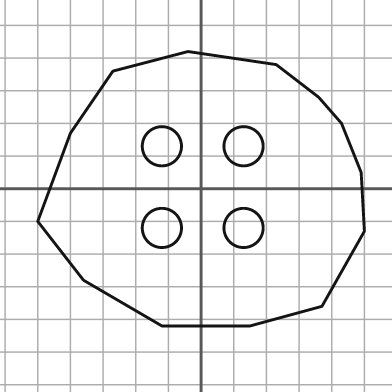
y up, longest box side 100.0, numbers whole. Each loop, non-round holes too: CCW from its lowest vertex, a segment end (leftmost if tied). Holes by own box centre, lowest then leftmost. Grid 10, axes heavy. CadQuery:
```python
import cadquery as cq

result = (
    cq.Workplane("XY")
    .moveTo(-12.0, -42.0)
    .lineTo(15.0, -42.0)
    .lineTo(37.0, -36.0)
    .lineTo(50.0, -13.0)
    .lineTo(49.0, 5.0)
    .lineTo(43.0, 20.0)
    .lineTo(36.0, 28.0)
    .lineTo(23.0, 38.0)
    .lineTo(-4.0, 42.0)
    .lineTo(-27.0, 36.0)
    .lineTo(-40.0, 17.0)
    .lineTo(-50.0, -10.0)
    .lineTo(-36.0, -28.0)
    .close()
    .moveTo(-12.0, -12.0)
    .circle(6.0)
    .moveTo(13.0, -12.0)
    .circle(6.0)
    .moveTo(-12.0, 13.0)
    .circle(6.0)
    .moveTo(13.0, 13.0)
    .circle(6.0)
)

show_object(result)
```